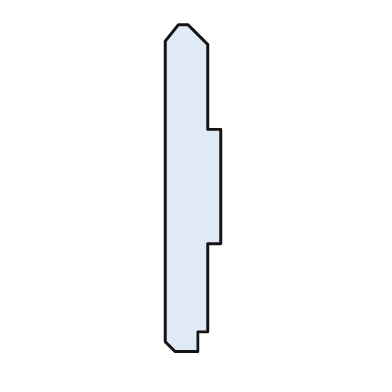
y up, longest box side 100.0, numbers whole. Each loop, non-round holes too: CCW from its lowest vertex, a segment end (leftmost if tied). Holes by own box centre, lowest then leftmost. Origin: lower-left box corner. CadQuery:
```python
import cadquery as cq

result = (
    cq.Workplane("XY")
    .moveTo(3.0, 0.0)
    .lineTo(10.0, 0.0)
    .lineTo(10.0, 6.0)
    .lineTo(13.0, 6.0)
    .lineTo(13.0, 33.0)
    .lineTo(17.0, 33.0)
    .lineTo(17.0, 68.0)
    .lineTo(13.0, 68.0)
    .lineTo(13.0, 94.0)
    .lineTo(7.0, 100.0)
    .lineTo(4.0, 100.0)
    .lineTo(0.0, 95.0)
    .lineTo(0.0, 3.0)
    .close()
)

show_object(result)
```